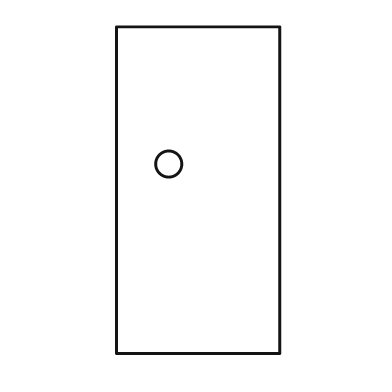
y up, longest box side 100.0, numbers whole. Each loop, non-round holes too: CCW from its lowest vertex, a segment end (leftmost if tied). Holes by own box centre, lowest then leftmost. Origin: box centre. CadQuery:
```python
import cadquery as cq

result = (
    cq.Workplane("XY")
    .moveTo(-25.0, -50.0)
    .lineTo(25.0, -50.0)
    .lineTo(25.0, 50.0)
    .lineTo(-25.0, 50.0)
    .close()
    .moveTo(-9.0, 8.0)
    .circle(4.0)
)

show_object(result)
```